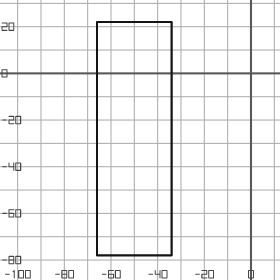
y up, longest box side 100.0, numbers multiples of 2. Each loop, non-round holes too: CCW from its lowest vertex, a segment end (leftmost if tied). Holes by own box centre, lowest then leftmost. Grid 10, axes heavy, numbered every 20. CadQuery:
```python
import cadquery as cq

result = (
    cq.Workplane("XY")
    .moveTo(-66.0, -78.0)
    .lineTo(-34.0, -78.0)
    .lineTo(-34.0, 22.0)
    .lineTo(-66.0, 22.0)
    .close()
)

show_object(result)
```